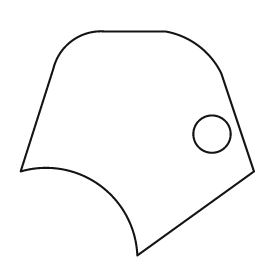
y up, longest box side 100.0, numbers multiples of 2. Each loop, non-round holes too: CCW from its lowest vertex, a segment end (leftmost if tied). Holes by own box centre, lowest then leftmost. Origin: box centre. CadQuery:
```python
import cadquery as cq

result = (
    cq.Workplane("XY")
    .moveTo(0.0, -48.0)
    .lineTo(50.0, -12.0)
    .lineTo(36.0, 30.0)
    .threePointArc((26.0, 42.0), (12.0, 48.0))
    .lineTo(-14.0, 48.0)
    .threePointArc((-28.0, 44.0), (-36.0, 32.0))
    .lineTo(-50.0, -12.0)
    .threePointArc((-16.0, -18.0), (0.0, -48.0))
    .close()
    .moveTo(32.0, 4.0)
    .circle(8.0)
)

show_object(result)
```